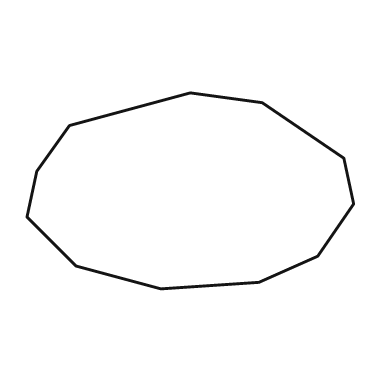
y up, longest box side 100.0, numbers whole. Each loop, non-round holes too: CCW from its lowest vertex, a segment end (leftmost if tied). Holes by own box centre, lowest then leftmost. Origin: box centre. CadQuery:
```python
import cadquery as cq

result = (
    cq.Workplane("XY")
    .moveTo(-9.0, -30.0)
    .lineTo(21.0, -28.0)
    .lineTo(39.0, -20.0)
    .lineTo(50.0, -4.0)
    .lineTo(47.0, 10.0)
    .lineTo(22.0, 27.0)
    .lineTo(0.0, 30.0)
    .lineTo(-37.0, 20.0)
    .lineTo(-47.0, 6.0)
    .lineTo(-50.0, -8.0)
    .lineTo(-35.0, -23.0)
    .close()
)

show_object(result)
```